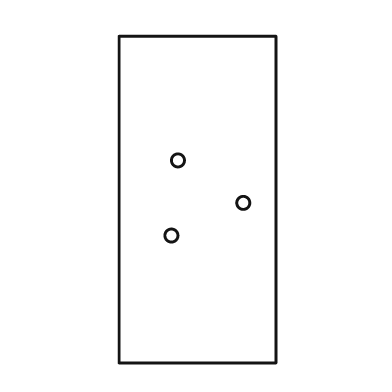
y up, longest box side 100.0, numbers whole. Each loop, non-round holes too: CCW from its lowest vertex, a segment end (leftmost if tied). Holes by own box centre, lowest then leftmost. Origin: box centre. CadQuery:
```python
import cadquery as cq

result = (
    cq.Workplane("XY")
    .moveTo(-24.0, -50.0)
    .lineTo(24.0, -50.0)
    .lineTo(24.0, 50.0)
    .lineTo(-24.0, 50.0)
    .close()
    .moveTo(-8.0, -11.0)
    .circle(2.0)
    .moveTo(14.0, -1.0)
    .circle(2.0)
    .moveTo(-6.0, 12.0)
    .circle(2.0)
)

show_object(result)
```